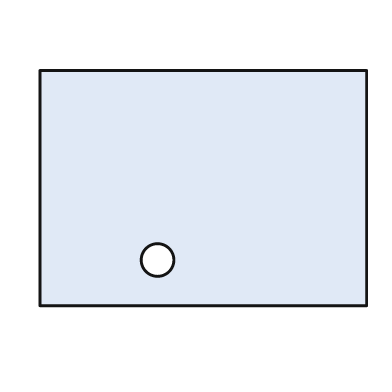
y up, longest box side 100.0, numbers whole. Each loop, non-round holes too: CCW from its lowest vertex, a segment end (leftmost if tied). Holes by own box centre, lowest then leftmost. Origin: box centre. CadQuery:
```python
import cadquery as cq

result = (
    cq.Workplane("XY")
    .moveTo(-50.0, -36.0)
    .lineTo(50.0, -36.0)
    .lineTo(50.0, 36.0)
    .lineTo(-50.0, 36.0)
    .close()
    .moveTo(-14.0, -22.0)
    .circle(5.0)
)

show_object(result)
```